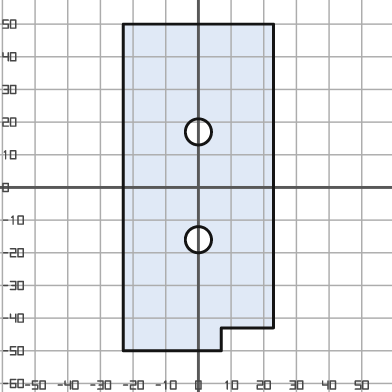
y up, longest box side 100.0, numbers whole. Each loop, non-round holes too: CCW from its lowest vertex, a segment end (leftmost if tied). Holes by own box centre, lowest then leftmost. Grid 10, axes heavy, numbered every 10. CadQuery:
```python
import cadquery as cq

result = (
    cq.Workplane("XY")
    .moveTo(-23.0, -50.0)
    .lineTo(7.0, -50.0)
    .lineTo(7.0, -43.0)
    .lineTo(23.0, -43.0)
    .lineTo(23.0, 50.0)
    .lineTo(-23.0, 50.0)
    .close()
    .moveTo(0.0, -16.0)
    .circle(4.0)
    .moveTo(0.0, 17.0)
    .circle(4.0)
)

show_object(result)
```